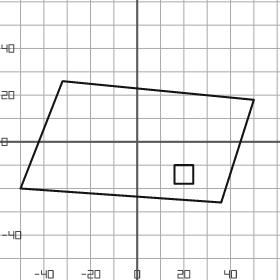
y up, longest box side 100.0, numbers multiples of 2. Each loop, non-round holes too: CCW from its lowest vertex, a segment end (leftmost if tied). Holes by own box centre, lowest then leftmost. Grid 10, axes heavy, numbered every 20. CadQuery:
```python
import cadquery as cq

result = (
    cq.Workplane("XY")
    .moveTo(36.0, -26.0)
    .lineTo(50.0, 18.0)
    .lineTo(-32.0, 26.0)
    .lineTo(-50.0, -20.0)
    .close()
    .moveTo(16.0, -18.0)
    .lineTo(24.0, -18.0)
    .lineTo(24.0, -10.0)
    .lineTo(16.0, -10.0)
    .close()
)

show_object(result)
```